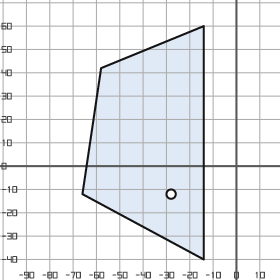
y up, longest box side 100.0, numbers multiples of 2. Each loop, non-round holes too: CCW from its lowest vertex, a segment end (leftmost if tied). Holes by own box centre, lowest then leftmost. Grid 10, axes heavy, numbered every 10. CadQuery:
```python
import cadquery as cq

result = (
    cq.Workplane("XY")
    .moveTo(-14.0, -40.0)
    .lineTo(-14.0, 60.0)
    .lineTo(-58.0, 42.0)
    .lineTo(-66.0, -12.0)
    .close()
    .moveTo(-28.0, -12.0)
    .circle(2.0)
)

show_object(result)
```